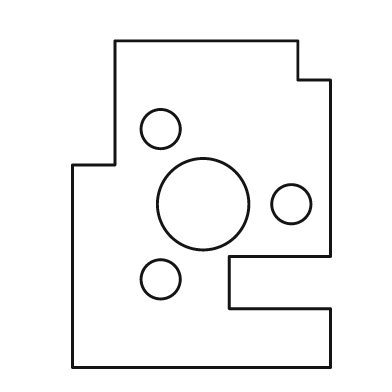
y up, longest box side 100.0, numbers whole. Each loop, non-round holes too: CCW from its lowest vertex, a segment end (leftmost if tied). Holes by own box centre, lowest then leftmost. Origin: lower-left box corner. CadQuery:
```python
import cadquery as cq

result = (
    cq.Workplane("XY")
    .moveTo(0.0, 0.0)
    .lineTo(79.0, 0.0)
    .lineTo(79.0, 18.0)
    .lineTo(48.0, 18.0)
    .lineTo(48.0, 34.0)
    .lineTo(79.0, 34.0)
    .lineTo(79.0, 88.0)
    .lineTo(69.0, 88.0)
    .lineTo(69.0, 100.0)
    .lineTo(13.0, 100.0)
    .lineTo(13.0, 62.0)
    .lineTo(0.0, 62.0)
    .close()
    .moveTo(27.0, 27.0)
    .circle(6.0)
    .moveTo(40.0, 50.0)
    .circle(14.0)
    .moveTo(67.0, 50.0)
    .circle(6.0)
    .moveTo(27.0, 73.0)
    .circle(6.0)
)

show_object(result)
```